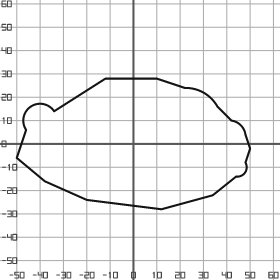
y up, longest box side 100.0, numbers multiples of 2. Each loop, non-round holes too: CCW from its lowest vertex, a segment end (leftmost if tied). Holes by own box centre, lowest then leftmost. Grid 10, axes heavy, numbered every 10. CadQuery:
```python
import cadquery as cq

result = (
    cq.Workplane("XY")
    .moveTo(12.0, -28.0)
    .lineTo(34.0, -22.0)
    .lineTo(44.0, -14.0)
    .threePointArc((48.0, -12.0), (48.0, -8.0))
    .lineTo(50.0, -2.0)
    .lineTo(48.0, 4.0)
    .threePointArc((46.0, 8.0), (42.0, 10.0))
    .lineTo(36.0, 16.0)
    .threePointArc((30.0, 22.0), (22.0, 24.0))
    .lineTo(10.0, 28.0)
    .lineTo(-12.0, 28.0)
    .lineTo(-34.0, 14.0)
    .threePointArc((-44.0, 16.0), (-46.0, 6.0))
    .lineTo(-50.0, -6.0)
    .lineTo(-38.0, -16.0)
    .lineTo(-20.0, -24.0)
    .close()
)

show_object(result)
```